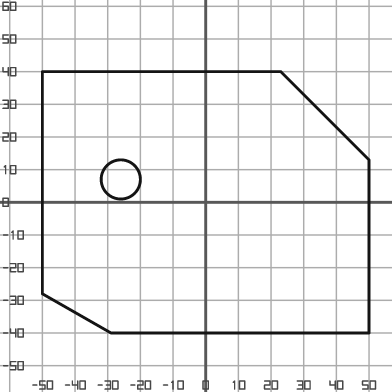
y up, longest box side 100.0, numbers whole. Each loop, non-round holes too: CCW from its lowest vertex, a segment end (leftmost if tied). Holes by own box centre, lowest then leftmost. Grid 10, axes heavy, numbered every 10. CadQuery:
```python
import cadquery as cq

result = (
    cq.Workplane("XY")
    .moveTo(-29.0, -40.0)
    .lineTo(50.0, -40.0)
    .lineTo(50.0, 13.0)
    .lineTo(23.0, 40.0)
    .lineTo(-50.0, 40.0)
    .lineTo(-50.0, -28.0)
    .close()
    .moveTo(-26.0, 7.0)
    .circle(6.0)
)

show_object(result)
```